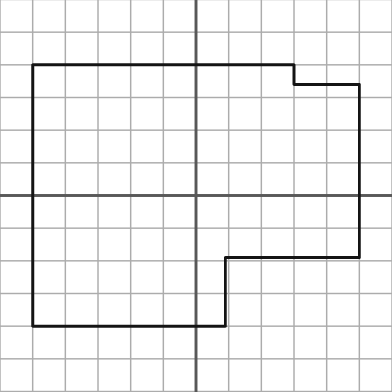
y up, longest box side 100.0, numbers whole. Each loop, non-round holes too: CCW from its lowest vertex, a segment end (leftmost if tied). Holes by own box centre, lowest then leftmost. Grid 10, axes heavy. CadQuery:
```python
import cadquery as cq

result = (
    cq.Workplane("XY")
    .moveTo(-50.0, -40.0)
    .lineTo(9.0, -40.0)
    .lineTo(9.0, -19.0)
    .lineTo(50.0, -19.0)
    .lineTo(50.0, 34.0)
    .lineTo(30.0, 34.0)
    .lineTo(30.0, 40.0)
    .lineTo(-50.0, 40.0)
    .close()
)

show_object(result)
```